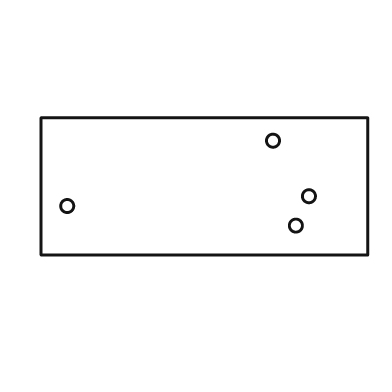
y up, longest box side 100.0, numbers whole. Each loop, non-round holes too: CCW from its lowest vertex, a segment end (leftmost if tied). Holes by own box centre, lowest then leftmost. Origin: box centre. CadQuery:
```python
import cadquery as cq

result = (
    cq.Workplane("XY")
    .moveTo(-50.0, -21.0)
    .lineTo(50.0, -21.0)
    .lineTo(50.0, 21.0)
    .lineTo(-50.0, 21.0)
    .close()
    .moveTo(28.0, -12.0)
    .circle(2.0)
    .moveTo(-42.0, -6.0)
    .circle(2.0)
    .moveTo(32.0, -3.0)
    .circle(2.0)
    .moveTo(21.0, 14.0)
    .circle(2.0)
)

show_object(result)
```